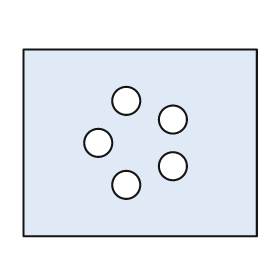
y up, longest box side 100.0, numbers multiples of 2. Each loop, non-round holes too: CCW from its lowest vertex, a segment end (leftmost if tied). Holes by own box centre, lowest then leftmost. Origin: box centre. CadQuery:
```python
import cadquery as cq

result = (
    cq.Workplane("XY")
    .moveTo(-50.0, -40.0)
    .lineTo(50.0, -40.0)
    .lineTo(50.0, 40.0)
    .lineTo(-50.0, 40.0)
    .close()
    .moveTo(-6.0, -18.0)
    .circle(6.0)
    .moveTo(14.0, -10.0)
    .circle(6.0)
    .moveTo(-18.0, 0.0)
    .circle(6.0)
    .moveTo(14.0, 10.0)
    .circle(6.0)
    .moveTo(-6.0, 18.0)
    .circle(6.0)
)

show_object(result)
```